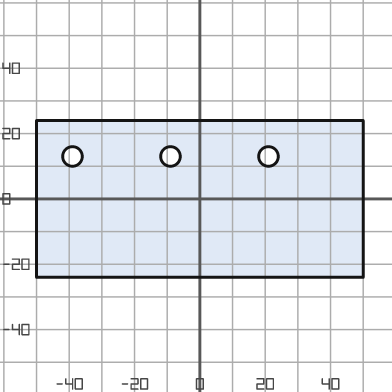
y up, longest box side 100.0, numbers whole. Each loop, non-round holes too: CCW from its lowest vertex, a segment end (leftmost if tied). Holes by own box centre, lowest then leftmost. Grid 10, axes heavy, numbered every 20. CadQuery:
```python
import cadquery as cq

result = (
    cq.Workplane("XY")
    .moveTo(-50.0, -24.0)
    .lineTo(50.0, -24.0)
    .lineTo(50.0, 24.0)
    .lineTo(-50.0, 24.0)
    .close()
    .moveTo(-39.0, 13.0)
    .circle(3.0)
    .moveTo(-9.0, 13.0)
    .circle(3.0)
    .moveTo(21.0, 13.0)
    .circle(3.0)
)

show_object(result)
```